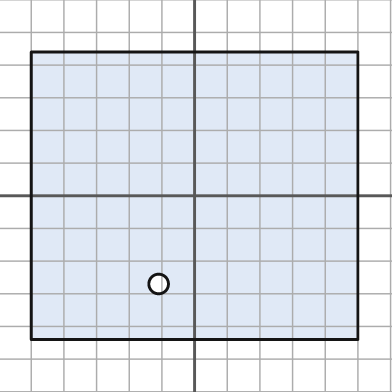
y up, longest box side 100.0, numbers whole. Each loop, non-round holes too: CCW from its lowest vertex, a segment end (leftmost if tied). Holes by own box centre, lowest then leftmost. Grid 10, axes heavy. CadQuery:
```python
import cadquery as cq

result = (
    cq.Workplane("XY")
    .moveTo(-50.0, -44.0)
    .lineTo(50.0, -44.0)
    .lineTo(50.0, 44.0)
    .lineTo(-50.0, 44.0)
    .close()
    .moveTo(-11.0, -27.0)
    .circle(3.0)
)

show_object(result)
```